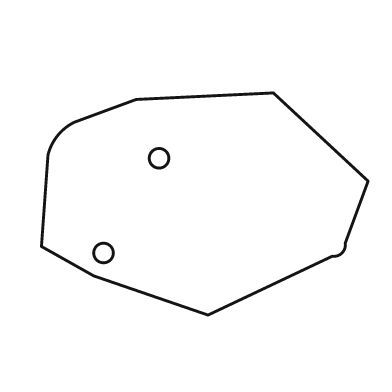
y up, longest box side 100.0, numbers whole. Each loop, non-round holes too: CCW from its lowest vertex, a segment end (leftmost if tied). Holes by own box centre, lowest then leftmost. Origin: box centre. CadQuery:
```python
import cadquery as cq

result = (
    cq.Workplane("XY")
    .moveTo(1.0, -34.0)
    .lineTo(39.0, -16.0)
    .threePointArc((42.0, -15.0), (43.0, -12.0))
    .lineTo(50.0, 7.0)
    .lineTo(21.0, 34.0)
    .lineTo(-21.0, 32.0)
    .lineTo(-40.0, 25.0)
    .threePointArc((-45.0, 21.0), (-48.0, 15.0))
    .lineTo(-50.0, -13.0)
    .lineTo(-34.0, -22.0)
    .close()
    .moveTo(-31.0, -15.0)
    .circle(3.0)
    .moveTo(-14.0, 14.0)
    .circle(3.0)
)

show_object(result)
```